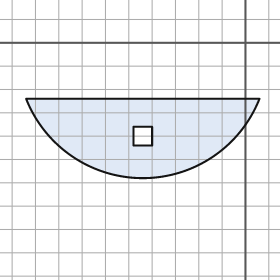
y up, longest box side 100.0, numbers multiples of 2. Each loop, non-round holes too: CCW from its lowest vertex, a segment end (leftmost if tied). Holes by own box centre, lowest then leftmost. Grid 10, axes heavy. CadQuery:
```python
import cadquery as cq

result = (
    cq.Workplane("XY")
    .moveTo(-94.0, -24.0)
    .threePointArc((-44.0, -58.0), (6.0, -24.0))
    .close()
    .moveTo(-48.0, -44.0)
    .lineTo(-40.0, -44.0)
    .lineTo(-40.0, -36.0)
    .lineTo(-48.0, -36.0)
    .close()
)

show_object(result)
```